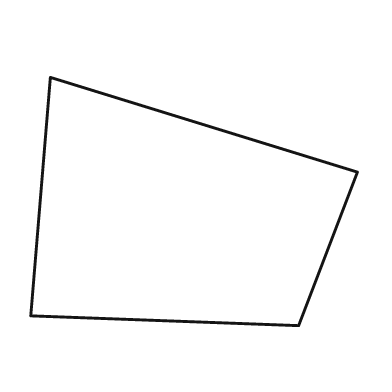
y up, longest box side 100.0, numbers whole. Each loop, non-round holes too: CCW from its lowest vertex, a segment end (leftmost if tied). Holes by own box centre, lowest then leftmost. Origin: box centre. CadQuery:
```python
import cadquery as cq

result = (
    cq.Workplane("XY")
    .moveTo(32.0, -38.0)
    .lineTo(50.0, 9.0)
    .lineTo(-44.0, 38.0)
    .lineTo(-50.0, -35.0)
    .close()
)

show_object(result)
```